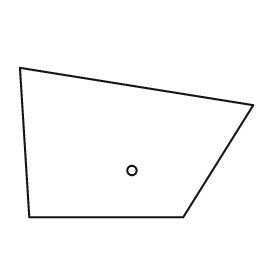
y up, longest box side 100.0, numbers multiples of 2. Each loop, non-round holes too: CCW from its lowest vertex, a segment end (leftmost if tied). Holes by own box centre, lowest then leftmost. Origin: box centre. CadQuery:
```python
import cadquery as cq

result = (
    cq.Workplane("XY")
    .moveTo(-46.0, -32.0)
    .lineTo(20.0, -32.0)
    .lineTo(50.0, 16.0)
    .lineTo(-50.0, 32.0)
    .close()
    .moveTo(-2.0, -12.0)
    .circle(2.0)
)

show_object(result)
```